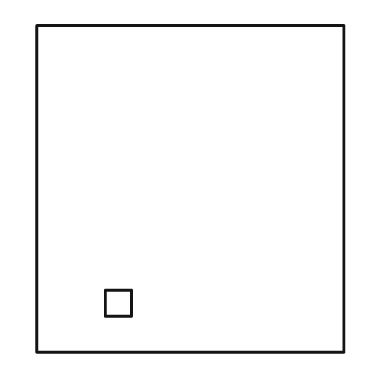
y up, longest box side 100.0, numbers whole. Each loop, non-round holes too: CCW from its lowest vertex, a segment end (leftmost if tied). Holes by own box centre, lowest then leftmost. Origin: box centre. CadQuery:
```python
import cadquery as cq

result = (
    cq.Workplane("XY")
    .moveTo(-47.0, -50.0)
    .lineTo(47.0, -50.0)
    .lineTo(47.0, 50.0)
    .lineTo(-47.0, 50.0)
    .close()
    .moveTo(-26.0, -39.0)
    .lineTo(-18.0, -39.0)
    .lineTo(-18.0, -31.0)
    .lineTo(-26.0, -31.0)
    .close()
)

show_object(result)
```